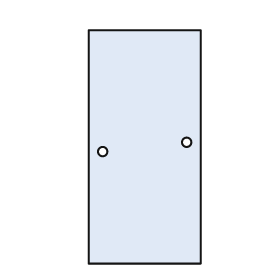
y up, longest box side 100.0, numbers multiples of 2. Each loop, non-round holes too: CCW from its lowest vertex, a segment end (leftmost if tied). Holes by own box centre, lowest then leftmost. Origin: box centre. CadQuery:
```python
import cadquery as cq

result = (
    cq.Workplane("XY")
    .moveTo(-24.0, -50.0)
    .lineTo(24.0, -50.0)
    .lineTo(24.0, 50.0)
    .lineTo(-24.0, 50.0)
    .close()
    .moveTo(-18.0, -2.0)
    .circle(2.0)
    .moveTo(18.0, 2.0)
    .circle(2.0)
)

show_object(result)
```